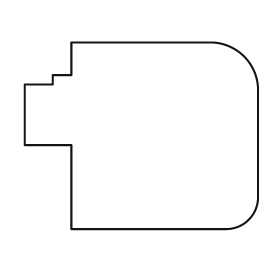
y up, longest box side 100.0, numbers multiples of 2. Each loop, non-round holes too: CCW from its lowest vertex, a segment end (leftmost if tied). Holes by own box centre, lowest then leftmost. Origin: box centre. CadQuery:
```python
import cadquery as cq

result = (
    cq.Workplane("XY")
    .moveTo(-30.0, -40.0)
    .lineTo(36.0, -40.0)
    .threePointArc((46.0, -36.0), (50.0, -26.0))
    .lineTo(50.0, 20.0)
    .threePointArc((44.0, 34.0), (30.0, 40.0))
    .lineTo(-30.0, 40.0)
    .lineTo(-30.0, 26.0)
    .lineTo(-38.0, 26.0)
    .lineTo(-38.0, 22.0)
    .lineTo(-50.0, 22.0)
    .lineTo(-50.0, -4.0)
    .lineTo(-30.0, -4.0)
    .close()
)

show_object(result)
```